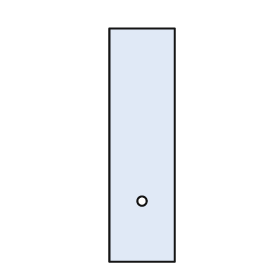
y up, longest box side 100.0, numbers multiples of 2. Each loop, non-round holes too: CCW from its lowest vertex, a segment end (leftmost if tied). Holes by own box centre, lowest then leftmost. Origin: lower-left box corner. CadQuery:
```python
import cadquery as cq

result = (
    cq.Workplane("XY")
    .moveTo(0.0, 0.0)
    .lineTo(28.0, 0.0)
    .lineTo(28.0, 100.0)
    .lineTo(0.0, 100.0)
    .close()
    .moveTo(14.0, 26.0)
    .circle(2.0)
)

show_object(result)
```